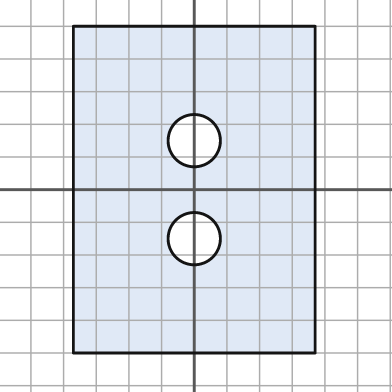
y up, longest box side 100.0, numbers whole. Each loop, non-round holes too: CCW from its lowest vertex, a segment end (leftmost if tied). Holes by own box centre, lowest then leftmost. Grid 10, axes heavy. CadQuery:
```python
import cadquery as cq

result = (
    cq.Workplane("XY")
    .moveTo(-37.0, -50.0)
    .lineTo(37.0, -50.0)
    .lineTo(37.0, 50.0)
    .lineTo(-37.0, 50.0)
    .close()
    .moveTo(0.0, -15.0)
    .circle(8.0)
    .moveTo(0.0, 15.0)
    .circle(8.0)
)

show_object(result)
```